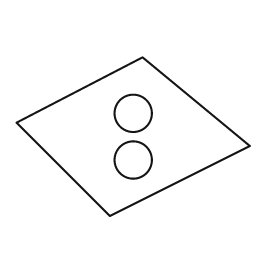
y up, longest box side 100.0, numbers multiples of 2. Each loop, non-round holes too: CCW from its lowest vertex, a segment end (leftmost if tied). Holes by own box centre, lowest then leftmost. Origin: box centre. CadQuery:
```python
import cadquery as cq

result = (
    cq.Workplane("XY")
    .moveTo(-10.0, -34.0)
    .lineTo(50.0, -4.0)
    .lineTo(4.0, 34.0)
    .lineTo(-50.0, 6.0)
    .close()
    .moveTo(0.0, -10.0)
    .circle(8.0)
    .moveTo(0.0, 10.0)
    .circle(8.0)
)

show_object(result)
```